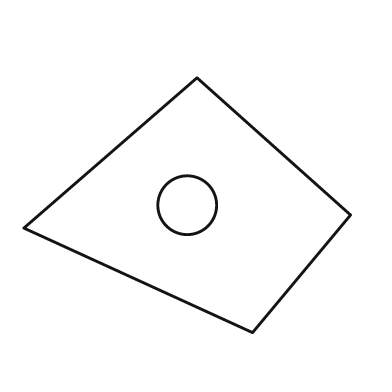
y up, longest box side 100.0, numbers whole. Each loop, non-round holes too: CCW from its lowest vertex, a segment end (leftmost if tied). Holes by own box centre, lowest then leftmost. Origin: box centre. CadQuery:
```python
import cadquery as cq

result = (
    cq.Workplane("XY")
    .moveTo(20.0, -39.0)
    .lineTo(50.0, -3.0)
    .lineTo(3.0, 39.0)
    .lineTo(-50.0, -7.0)
    .close()
    .moveTo(0.0, 0.0)
    .circle(9.0)
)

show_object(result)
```